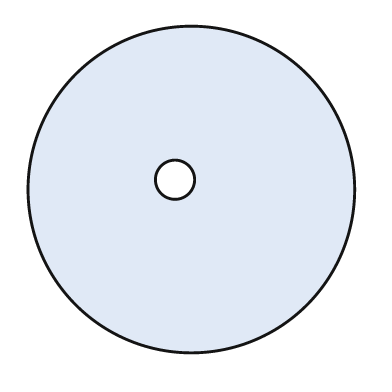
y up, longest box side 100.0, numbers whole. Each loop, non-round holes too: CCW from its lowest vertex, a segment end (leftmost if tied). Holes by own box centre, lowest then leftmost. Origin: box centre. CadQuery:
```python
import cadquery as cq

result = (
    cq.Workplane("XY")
    .moveTo(0.0, 0.0)
    .circle(50.0)
    .moveTo(-5.0, 3.0)
    .circle(6.0)
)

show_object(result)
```